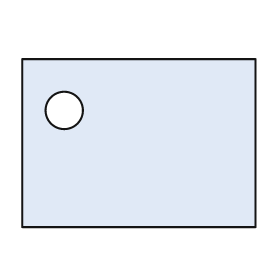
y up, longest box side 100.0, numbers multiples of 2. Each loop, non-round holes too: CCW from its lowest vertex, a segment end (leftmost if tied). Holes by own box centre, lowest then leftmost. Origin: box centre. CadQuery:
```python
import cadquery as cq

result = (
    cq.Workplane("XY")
    .moveTo(-50.0, -36.0)
    .lineTo(50.0, -36.0)
    .lineTo(50.0, 36.0)
    .lineTo(-50.0, 36.0)
    .close()
    .moveTo(-32.0, 14.0)
    .circle(8.0)
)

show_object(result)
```